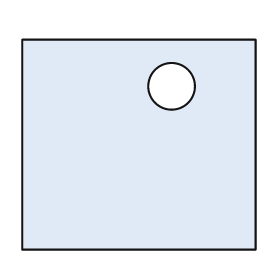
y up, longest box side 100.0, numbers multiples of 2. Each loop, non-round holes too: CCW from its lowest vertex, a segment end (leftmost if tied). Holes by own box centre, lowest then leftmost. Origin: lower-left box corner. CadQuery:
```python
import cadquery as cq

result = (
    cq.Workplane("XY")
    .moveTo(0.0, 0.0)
    .lineTo(100.0, 0.0)
    .lineTo(100.0, 90.0)
    .lineTo(0.0, 90.0)
    .close()
    .moveTo(64.0, 70.0)
    .circle(10.0)
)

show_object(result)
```